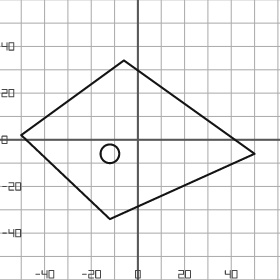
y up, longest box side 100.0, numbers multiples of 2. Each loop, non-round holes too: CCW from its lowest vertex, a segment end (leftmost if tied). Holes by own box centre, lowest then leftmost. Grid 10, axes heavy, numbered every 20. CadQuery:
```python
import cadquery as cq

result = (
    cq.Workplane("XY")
    .moveTo(-12.0, -34.0)
    .lineTo(50.0, -6.0)
    .lineTo(-6.0, 34.0)
    .lineTo(-50.0, 2.0)
    .close()
    .moveTo(-12.0, -6.0)
    .circle(4.0)
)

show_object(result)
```